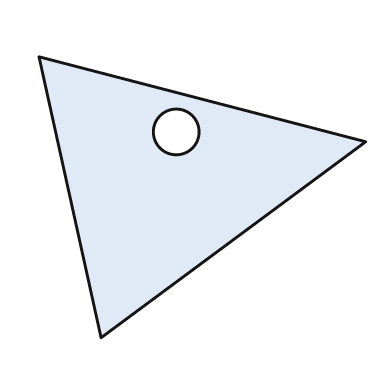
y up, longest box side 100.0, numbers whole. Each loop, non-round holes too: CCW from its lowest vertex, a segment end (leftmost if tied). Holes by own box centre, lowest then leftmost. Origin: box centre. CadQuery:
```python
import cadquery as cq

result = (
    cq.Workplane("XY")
    .moveTo(-31.0, -43.0)
    .lineTo(50.0, 17.0)
    .lineTo(-50.0, 43.0)
    .close()
    .moveTo(-8.0, 20.0)
    .circle(7.0)
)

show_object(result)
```